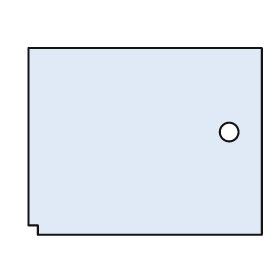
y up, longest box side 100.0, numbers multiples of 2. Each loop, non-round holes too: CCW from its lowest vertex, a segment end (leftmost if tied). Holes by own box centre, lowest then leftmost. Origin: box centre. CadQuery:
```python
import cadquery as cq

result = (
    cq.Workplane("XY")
    .moveTo(-46.0, -40.0)
    .lineTo(50.0, -40.0)
    .lineTo(50.0, 40.0)
    .lineTo(-50.0, 40.0)
    .lineTo(-50.0, -36.0)
    .lineTo(-46.0, -36.0)
    .close()
    .moveTo(36.0, 4.0)
    .circle(4.0)
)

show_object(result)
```